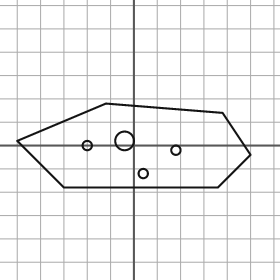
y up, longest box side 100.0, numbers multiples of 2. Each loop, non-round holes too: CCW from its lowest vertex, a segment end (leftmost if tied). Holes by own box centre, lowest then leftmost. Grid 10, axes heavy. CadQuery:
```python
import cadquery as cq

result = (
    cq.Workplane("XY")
    .moveTo(-30.0, -18.0)
    .lineTo(36.0, -18.0)
    .lineTo(50.0, -4.0)
    .lineTo(38.0, 14.0)
    .lineTo(-12.0, 18.0)
    .lineTo(-50.0, 2.0)
    .close()
    .moveTo(4.0, -12.0)
    .circle(2.0)
    .moveTo(18.0, -2.0)
    .circle(2.0)
    .moveTo(-20.0, 0.0)
    .circle(2.0)
    .moveTo(-4.0, 2.0)
    .circle(4.0)
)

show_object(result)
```